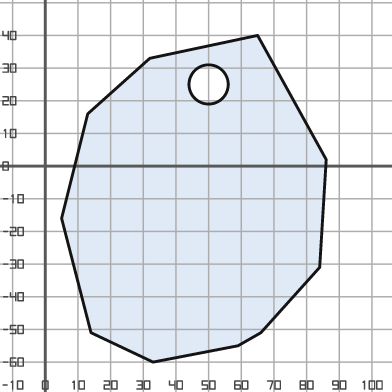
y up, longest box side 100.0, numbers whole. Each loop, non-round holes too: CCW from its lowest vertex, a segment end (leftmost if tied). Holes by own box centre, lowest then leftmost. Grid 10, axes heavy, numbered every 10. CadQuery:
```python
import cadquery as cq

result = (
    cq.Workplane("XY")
    .moveTo(33.0, -60.0)
    .lineTo(59.0, -55.0)
    .lineTo(66.0, -51.0)
    .lineTo(84.0, -31.0)
    .lineTo(86.0, 2.0)
    .lineTo(65.0, 40.0)
    .lineTo(32.0, 33.0)
    .lineTo(13.0, 16.0)
    .lineTo(5.0, -16.0)
    .lineTo(14.0, -51.0)
    .close()
    .moveTo(50.0, 25.0)
    .circle(6.0)
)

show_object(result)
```